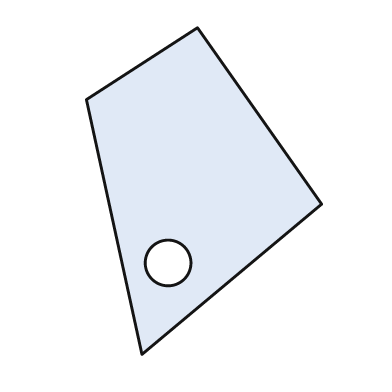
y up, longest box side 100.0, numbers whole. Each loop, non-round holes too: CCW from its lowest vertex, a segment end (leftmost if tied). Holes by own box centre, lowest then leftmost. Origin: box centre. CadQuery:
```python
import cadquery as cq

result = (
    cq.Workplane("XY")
    .moveTo(-19.0, -50.0)
    .lineTo(36.0, -4.0)
    .lineTo(-2.0, 50.0)
    .lineTo(-36.0, 28.0)
    .close()
    .moveTo(-11.0, -22.0)
    .circle(7.0)
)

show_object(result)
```